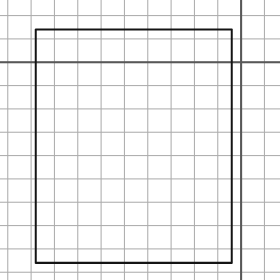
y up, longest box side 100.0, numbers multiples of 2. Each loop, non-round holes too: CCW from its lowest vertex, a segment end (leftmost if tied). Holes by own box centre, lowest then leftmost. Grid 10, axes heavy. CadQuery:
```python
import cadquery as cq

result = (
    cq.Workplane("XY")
    .moveTo(-88.0, -86.0)
    .lineTo(-4.0, -86.0)
    .lineTo(-4.0, 14.0)
    .lineTo(-88.0, 14.0)
    .close()
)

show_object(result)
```